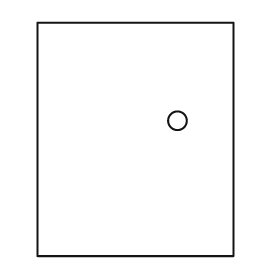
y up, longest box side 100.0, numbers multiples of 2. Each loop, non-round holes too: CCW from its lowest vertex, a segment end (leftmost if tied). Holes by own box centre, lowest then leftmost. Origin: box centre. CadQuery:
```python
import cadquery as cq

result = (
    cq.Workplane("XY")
    .moveTo(-42.0, -50.0)
    .lineTo(42.0, -50.0)
    .lineTo(42.0, 50.0)
    .lineTo(-42.0, 50.0)
    .close()
    .moveTo(18.0, 8.0)
    .circle(4.0)
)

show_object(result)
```